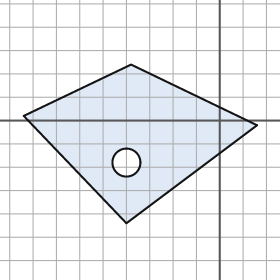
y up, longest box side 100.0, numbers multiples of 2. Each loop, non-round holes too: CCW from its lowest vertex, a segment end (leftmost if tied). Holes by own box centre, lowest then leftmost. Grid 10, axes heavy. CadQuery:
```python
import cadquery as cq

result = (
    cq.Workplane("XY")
    .moveTo(-40.0, -44.0)
    .lineTo(16.0, -2.0)
    .lineTo(-38.0, 24.0)
    .lineTo(-84.0, 2.0)
    .close()
    .moveTo(-40.0, -18.0)
    .circle(6.0)
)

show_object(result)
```